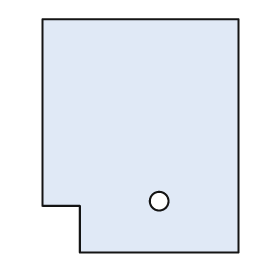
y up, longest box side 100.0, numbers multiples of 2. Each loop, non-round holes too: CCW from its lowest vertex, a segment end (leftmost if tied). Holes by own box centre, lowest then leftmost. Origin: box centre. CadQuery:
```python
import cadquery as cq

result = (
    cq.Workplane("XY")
    .moveTo(-26.0, -50.0)
    .lineTo(42.0, -50.0)
    .lineTo(42.0, 50.0)
    .lineTo(-42.0, 50.0)
    .lineTo(-42.0, -30.0)
    .lineTo(-26.0, -30.0)
    .close()
    .moveTo(8.0, -28.0)
    .circle(4.0)
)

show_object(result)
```